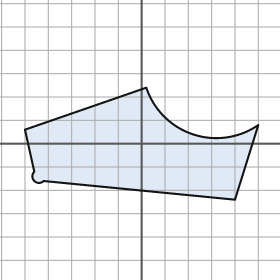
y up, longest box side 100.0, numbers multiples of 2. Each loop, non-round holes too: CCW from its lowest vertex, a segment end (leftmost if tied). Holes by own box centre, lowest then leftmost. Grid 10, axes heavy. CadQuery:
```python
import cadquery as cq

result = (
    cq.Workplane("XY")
    .moveTo(40.0, -24.0)
    .lineTo(50.0, 8.0)
    .threePointArc((22.0, 4.0), (2.0, 24.0))
    .lineTo(-50.0, 6.0)
    .lineTo(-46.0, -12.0)
    .threePointArc((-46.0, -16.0), (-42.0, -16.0))
    .close()
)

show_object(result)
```